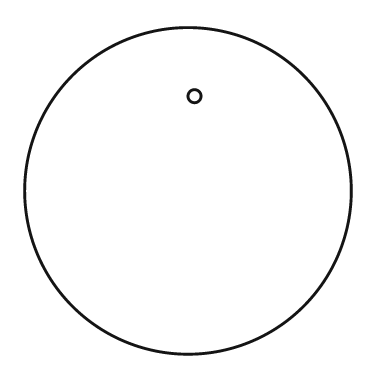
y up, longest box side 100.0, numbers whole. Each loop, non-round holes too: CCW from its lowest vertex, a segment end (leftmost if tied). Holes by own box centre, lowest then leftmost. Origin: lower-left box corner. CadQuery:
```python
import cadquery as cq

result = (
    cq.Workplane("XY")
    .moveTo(50.0, 50.0)
    .circle(50.0)
    .moveTo(52.0, 79.0)
    .circle(2.0)
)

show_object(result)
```